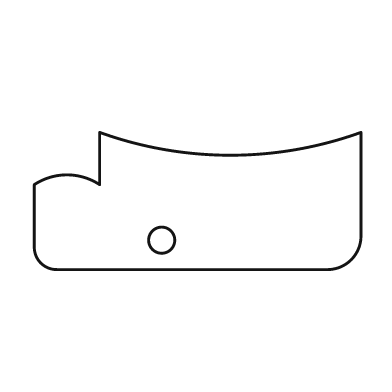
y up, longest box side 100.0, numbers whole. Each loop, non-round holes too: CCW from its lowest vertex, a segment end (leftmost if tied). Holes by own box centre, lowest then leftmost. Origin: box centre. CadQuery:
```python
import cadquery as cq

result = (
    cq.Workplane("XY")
    .moveTo(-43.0, -21.0)
    .lineTo(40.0, -21.0)
    .threePointArc((47.0, -18.0), (50.0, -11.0))
    .lineTo(50.0, 21.0)
    .threePointArc((10.0, 14.0), (-30.0, 21.0))
    .lineTo(-30.0, 5.0)
    .threePointArc((-40.0, 8.0), (-50.0, 5.0))
    .lineTo(-50.0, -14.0)
    .threePointArc((-48.0, -19.0), (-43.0, -21.0))
    .close()
    .moveTo(-11.0, -12.0)
    .circle(4.0)
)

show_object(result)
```